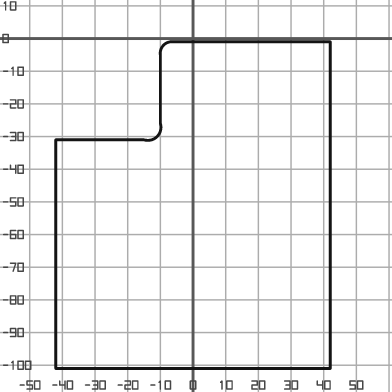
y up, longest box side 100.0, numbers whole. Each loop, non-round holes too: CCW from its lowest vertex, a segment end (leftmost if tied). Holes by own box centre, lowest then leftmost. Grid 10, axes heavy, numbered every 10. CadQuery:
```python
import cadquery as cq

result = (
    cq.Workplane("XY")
    .moveTo(-42.0, -101.0)
    .lineTo(42.0, -101.0)
    .lineTo(42.0, -1.0)
    .lineTo(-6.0, -1.0)
    .threePointArc((-9.0, -2.0), (-10.0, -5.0))
    .lineTo(-10.0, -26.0)
    .threePointArc((-11.0, -30.0), (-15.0, -31.0))
    .lineTo(-42.0, -31.0)
    .close()
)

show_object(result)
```